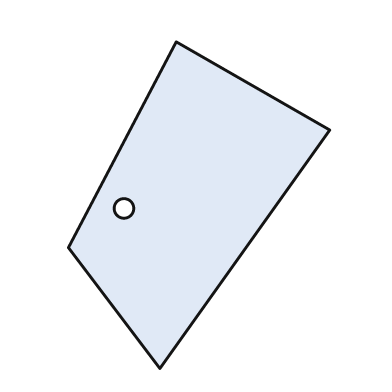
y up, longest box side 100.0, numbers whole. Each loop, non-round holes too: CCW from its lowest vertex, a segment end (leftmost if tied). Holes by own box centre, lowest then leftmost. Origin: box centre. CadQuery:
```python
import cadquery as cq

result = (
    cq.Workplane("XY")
    .moveTo(-12.0, -50.0)
    .lineTo(40.0, 23.0)
    .lineTo(-7.0, 50.0)
    .lineTo(-40.0, -13.0)
    .close()
    .moveTo(-23.0, -1.0)
    .circle(3.0)
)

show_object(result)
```